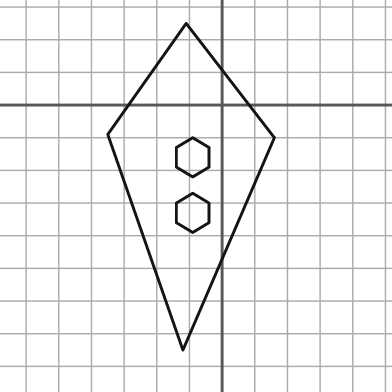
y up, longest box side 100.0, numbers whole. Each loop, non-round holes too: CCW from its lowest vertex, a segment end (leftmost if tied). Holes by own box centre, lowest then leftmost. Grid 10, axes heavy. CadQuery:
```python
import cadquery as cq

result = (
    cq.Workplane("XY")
    .moveTo(-12.0, -75.0)
    .lineTo(16.0, -10.0)
    .lineTo(-11.0, 25.0)
    .lineTo(-35.0, -9.0)
    .close()
    .moveTo(-9.0, -39.0)
    .lineTo(-4.0, -36.0)
    .lineTo(-4.0, -30.0)
    .lineTo(-9.0, -27.0)
    .lineTo(-14.0, -30.0)
    .lineTo(-14.0, -36.0)
    .close()
    .moveTo(-9.0, -22.0)
    .lineTo(-4.0, -19.0)
    .lineTo(-4.0, -13.0)
    .lineTo(-9.0, -10.0)
    .lineTo(-14.0, -13.0)
    .lineTo(-14.0, -19.0)
    .close()
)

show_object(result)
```